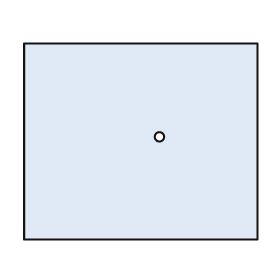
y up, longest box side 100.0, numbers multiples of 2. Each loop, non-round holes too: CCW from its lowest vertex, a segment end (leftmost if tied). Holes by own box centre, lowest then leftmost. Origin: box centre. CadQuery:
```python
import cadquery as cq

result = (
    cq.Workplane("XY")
    .moveTo(-50.0, -42.0)
    .lineTo(50.0, -42.0)
    .lineTo(50.0, 42.0)
    .lineTo(-50.0, 42.0)
    .close()
    .moveTo(8.0, 2.0)
    .circle(2.0)
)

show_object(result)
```